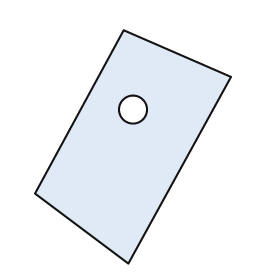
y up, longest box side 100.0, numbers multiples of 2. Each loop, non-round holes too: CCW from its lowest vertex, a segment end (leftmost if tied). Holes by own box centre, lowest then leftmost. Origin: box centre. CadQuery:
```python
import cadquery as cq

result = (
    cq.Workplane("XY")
    .moveTo(-2.0, -50.0)
    .lineTo(42.0, 30.0)
    .lineTo(-4.0, 50.0)
    .lineTo(-42.0, -20.0)
    .close()
    .moveTo(0.0, 16.0)
    .circle(6.0)
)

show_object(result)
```